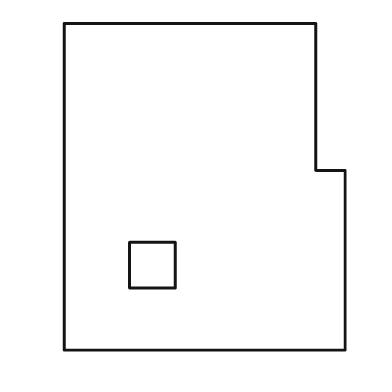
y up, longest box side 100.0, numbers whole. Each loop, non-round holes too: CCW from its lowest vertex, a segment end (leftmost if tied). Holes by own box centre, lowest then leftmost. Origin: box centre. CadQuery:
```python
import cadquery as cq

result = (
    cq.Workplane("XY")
    .moveTo(-43.0, -50.0)
    .lineTo(43.0, -50.0)
    .lineTo(43.0, 5.0)
    .lineTo(34.0, 5.0)
    .lineTo(34.0, 50.0)
    .lineTo(-43.0, 50.0)
    .close()
    .moveTo(-23.0, -31.0)
    .lineTo(-9.0, -31.0)
    .lineTo(-9.0, -17.0)
    .lineTo(-23.0, -17.0)
    .close()
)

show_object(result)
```